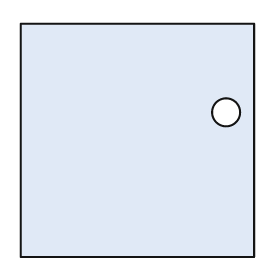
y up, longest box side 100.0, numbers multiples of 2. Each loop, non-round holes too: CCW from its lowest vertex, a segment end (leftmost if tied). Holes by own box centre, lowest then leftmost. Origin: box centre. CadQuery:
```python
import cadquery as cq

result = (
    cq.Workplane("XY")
    .moveTo(-50.0, -50.0)
    .lineTo(50.0, -50.0)
    .lineTo(50.0, 50.0)
    .lineTo(-50.0, 50.0)
    .close()
    .moveTo(38.0, 12.0)
    .circle(6.0)
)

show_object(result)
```